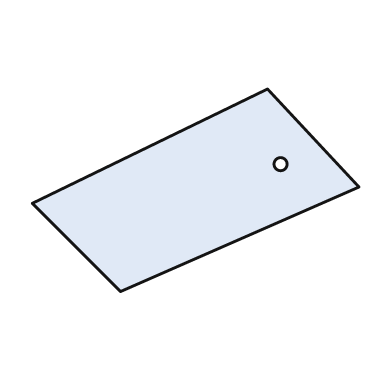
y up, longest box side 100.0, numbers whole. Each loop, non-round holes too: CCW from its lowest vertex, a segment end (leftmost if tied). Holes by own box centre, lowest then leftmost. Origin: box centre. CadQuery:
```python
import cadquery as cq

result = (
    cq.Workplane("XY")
    .moveTo(-23.0, -31.0)
    .lineTo(50.0, 1.0)
    .lineTo(22.0, 31.0)
    .lineTo(-50.0, -4.0)
    .close()
    .moveTo(26.0, 8.0)
    .circle(2.0)
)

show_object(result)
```